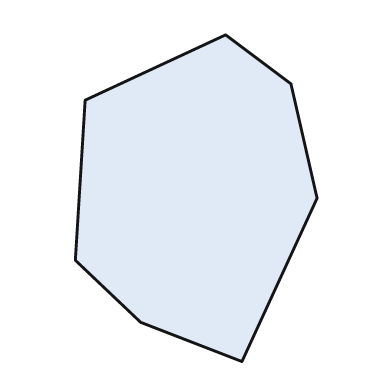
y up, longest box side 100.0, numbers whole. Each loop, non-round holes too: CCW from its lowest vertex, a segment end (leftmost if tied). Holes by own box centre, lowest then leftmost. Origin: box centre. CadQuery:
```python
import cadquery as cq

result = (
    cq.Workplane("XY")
    .moveTo(14.0, -50.0)
    .lineTo(37.0, 0.0)
    .lineTo(29.0, 35.0)
    .lineTo(9.0, 50.0)
    .lineTo(-34.0, 30.0)
    .lineTo(-37.0, -19.0)
    .lineTo(-17.0, -38.0)
    .close()
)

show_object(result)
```